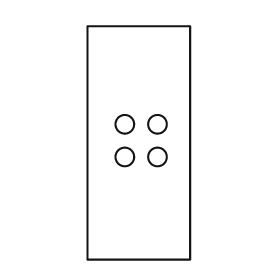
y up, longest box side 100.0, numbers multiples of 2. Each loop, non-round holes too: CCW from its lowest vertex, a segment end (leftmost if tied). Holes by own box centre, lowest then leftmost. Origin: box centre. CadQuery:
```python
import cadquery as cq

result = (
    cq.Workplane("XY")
    .moveTo(-22.0, -50.0)
    .lineTo(22.0, -50.0)
    .lineTo(22.0, 50.0)
    .lineTo(-22.0, 50.0)
    .close()
    .moveTo(-6.0, -6.0)
    .circle(4.0)
    .moveTo(8.0, -6.0)
    .circle(4.0)
    .moveTo(-6.0, 8.0)
    .circle(4.0)
    .moveTo(8.0, 8.0)
    .circle(4.0)
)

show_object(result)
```